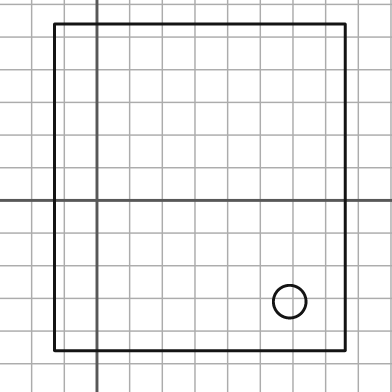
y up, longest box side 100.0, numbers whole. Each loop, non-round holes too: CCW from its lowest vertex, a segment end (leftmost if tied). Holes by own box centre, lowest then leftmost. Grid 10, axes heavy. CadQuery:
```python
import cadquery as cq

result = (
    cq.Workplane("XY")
    .moveTo(-13.0, -46.0)
    .lineTo(76.0, -46.0)
    .lineTo(76.0, 54.0)
    .lineTo(-13.0, 54.0)
    .close()
    .moveTo(59.0, -31.0)
    .circle(5.0)
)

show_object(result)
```